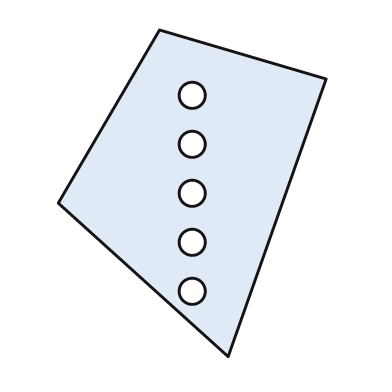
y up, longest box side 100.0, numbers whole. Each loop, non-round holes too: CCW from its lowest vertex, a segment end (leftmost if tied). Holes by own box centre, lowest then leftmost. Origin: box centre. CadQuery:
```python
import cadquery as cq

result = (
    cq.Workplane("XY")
    .moveTo(11.0, -50.0)
    .lineTo(41.0, 35.0)
    .lineTo(-10.0, 50.0)
    .lineTo(-41.0, -3.0)
    .close()
    .moveTo(0.0, -30.0)
    .circle(4.0)
    .moveTo(0.0, -15.0)
    .circle(4.0)
    .moveTo(0.0, 0.0)
    .circle(4.0)
    .moveTo(0.0, 15.0)
    .circle(4.0)
    .moveTo(0.0, 30.0)
    .circle(4.0)
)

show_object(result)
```